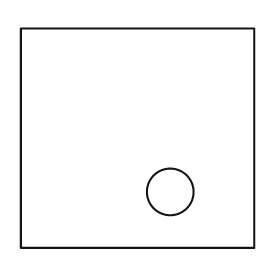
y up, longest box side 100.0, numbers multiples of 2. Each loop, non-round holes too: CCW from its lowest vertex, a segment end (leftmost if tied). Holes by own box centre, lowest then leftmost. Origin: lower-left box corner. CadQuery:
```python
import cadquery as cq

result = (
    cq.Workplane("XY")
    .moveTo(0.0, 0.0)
    .lineTo(100.0, 0.0)
    .lineTo(100.0, 94.0)
    .lineTo(0.0, 94.0)
    .close()
    .moveTo(64.0, 24.0)
    .circle(10.0)
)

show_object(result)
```